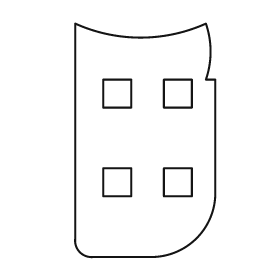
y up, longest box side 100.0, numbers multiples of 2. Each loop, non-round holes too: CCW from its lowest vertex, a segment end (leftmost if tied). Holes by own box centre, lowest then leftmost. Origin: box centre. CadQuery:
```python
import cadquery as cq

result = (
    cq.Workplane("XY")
    .moveTo(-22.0, -50.0)
    .lineTo(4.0, -50.0)
    .threePointArc((22.0, -42.0), (30.0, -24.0))
    .lineTo(30.0, 26.0)
    .lineTo(26.0, 26.0)
    .threePointArc((28.0, 38.0), (26.0, 50.0))
    .threePointArc((-2.0, 44.0), (-30.0, 50.0))
    .lineTo(-30.0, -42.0)
    .threePointArc((-28.0, -48.0), (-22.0, -50.0))
    .close()
    .moveTo(-18.0, -24.0)
    .lineTo(-6.0, -24.0)
    .lineTo(-6.0, -12.0)
    .lineTo(-18.0, -12.0)
    .close()
    .moveTo(8.0, -24.0)
    .lineTo(20.0, -24.0)
    .lineTo(20.0, -12.0)
    .lineTo(8.0, -12.0)
    .close()
    .moveTo(-18.0, 14.0)
    .lineTo(-6.0, 14.0)
    .lineTo(-6.0, 26.0)
    .lineTo(-18.0, 26.0)
    .close()
    .moveTo(8.0, 14.0)
    .lineTo(20.0, 14.0)
    .lineTo(20.0, 26.0)
    .lineTo(8.0, 26.0)
    .close()
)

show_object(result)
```